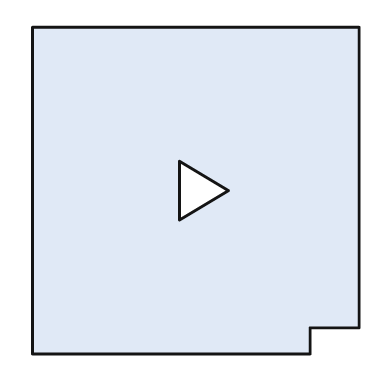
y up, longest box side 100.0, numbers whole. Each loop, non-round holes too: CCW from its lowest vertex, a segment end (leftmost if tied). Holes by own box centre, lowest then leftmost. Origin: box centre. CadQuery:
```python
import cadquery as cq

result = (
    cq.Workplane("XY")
    .moveTo(-50.0, -50.0)
    .lineTo(35.0, -50.0)
    .lineTo(35.0, -42.0)
    .lineTo(50.0, -42.0)
    .lineTo(50.0, 50.0)
    .lineTo(-50.0, 50.0)
    .close()
    .moveTo(-5.0, -9.0)
    .lineTo(10.0, 0.0)
    .lineTo(-5.0, 9.0)
    .close()
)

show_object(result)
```